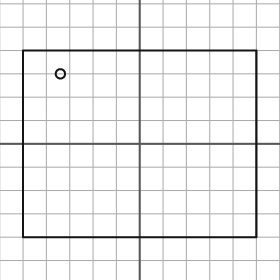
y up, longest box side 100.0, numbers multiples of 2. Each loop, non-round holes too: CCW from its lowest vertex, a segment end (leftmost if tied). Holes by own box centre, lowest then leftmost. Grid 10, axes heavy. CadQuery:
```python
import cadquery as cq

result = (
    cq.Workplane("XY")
    .moveTo(-50.0, -40.0)
    .lineTo(50.0, -40.0)
    .lineTo(50.0, 40.0)
    .lineTo(-50.0, 40.0)
    .close()
    .moveTo(-34.0, 30.0)
    .circle(2.0)
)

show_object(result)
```